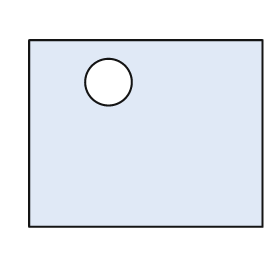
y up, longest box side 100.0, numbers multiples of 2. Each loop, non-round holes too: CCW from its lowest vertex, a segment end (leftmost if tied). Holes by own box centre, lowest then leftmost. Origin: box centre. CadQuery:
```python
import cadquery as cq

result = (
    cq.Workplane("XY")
    .moveTo(-50.0, -40.0)
    .lineTo(50.0, -40.0)
    .lineTo(50.0, 40.0)
    .lineTo(-50.0, 40.0)
    .close()
    .moveTo(-16.0, 22.0)
    .circle(10.0)
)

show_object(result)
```